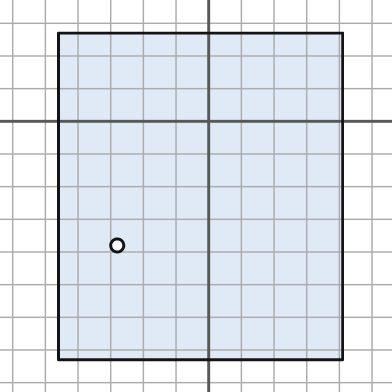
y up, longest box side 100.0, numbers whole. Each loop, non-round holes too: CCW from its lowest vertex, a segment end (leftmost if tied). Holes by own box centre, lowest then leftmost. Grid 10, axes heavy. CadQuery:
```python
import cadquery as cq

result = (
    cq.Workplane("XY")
    .moveTo(-46.0, -73.0)
    .lineTo(41.0, -73.0)
    .lineTo(41.0, 27.0)
    .lineTo(-46.0, 27.0)
    .close()
    .moveTo(-28.0, -38.0)
    .circle(2.0)
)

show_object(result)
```